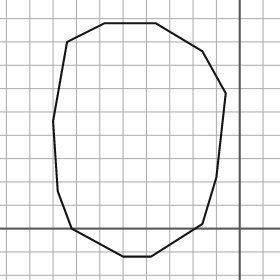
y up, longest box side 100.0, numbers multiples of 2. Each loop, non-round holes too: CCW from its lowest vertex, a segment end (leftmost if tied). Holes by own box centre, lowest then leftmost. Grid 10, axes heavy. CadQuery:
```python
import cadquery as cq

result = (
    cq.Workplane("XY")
    .moveTo(-50.0, -12.0)
    .lineTo(-38.0, -12.0)
    .lineTo(-16.0, 2.0)
    .lineTo(-10.0, 22.0)
    .lineTo(-6.0, 58.0)
    .lineTo(-16.0, 76.0)
    .lineTo(-36.0, 88.0)
    .lineTo(-58.0, 88.0)
    .lineTo(-74.0, 80.0)
    .lineTo(-80.0, 46.0)
    .lineTo(-78.0, 16.0)
    .lineTo(-72.0, 0.0)
    .close()
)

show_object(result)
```